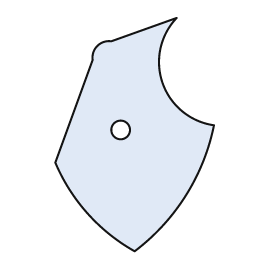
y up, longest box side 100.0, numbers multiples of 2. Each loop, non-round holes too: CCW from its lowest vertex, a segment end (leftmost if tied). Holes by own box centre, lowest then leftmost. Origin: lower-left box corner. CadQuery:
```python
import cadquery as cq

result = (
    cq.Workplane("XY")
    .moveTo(34.0, 0.0)
    .threePointArc((56.0, 24.0), (68.0, 54.0))
    .threePointArc((46.0, 72.0), (52.0, 100.0))
    .lineTo(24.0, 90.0)
    .threePointArc((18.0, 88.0), (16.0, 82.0))
    .lineTo(0.0, 38.0)
    .threePointArc((14.0, 16.0), (34.0, 0.0))
    .close()
    .moveTo(28.0, 52.0)
    .circle(4.0)
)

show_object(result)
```